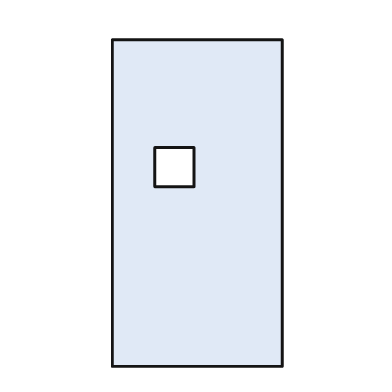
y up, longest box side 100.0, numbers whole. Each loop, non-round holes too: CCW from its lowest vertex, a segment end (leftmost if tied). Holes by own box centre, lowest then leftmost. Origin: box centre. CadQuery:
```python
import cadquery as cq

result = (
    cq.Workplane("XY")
    .moveTo(-26.0, -50.0)
    .lineTo(26.0, -50.0)
    .lineTo(26.0, 50.0)
    .lineTo(-26.0, 50.0)
    .close()
    .moveTo(-13.0, 5.0)
    .lineTo(-1.0, 5.0)
    .lineTo(-1.0, 17.0)
    .lineTo(-13.0, 17.0)
    .close()
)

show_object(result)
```